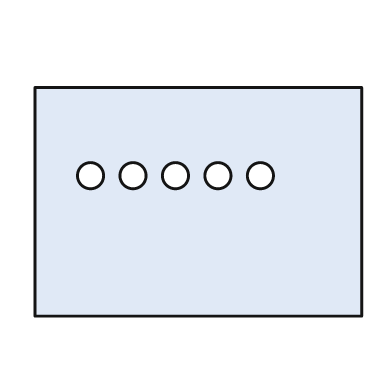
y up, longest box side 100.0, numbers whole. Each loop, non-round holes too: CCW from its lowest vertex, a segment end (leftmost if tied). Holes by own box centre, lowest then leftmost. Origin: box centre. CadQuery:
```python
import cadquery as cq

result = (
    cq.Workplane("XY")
    .moveTo(-50.0, -35.0)
    .lineTo(50.0, -35.0)
    .lineTo(50.0, 35.0)
    .lineTo(-50.0, 35.0)
    .close()
    .moveTo(-33.0, 8.0)
    .circle(4.0)
    .moveTo(-20.0, 8.0)
    .circle(4.0)
    .moveTo(-7.0, 8.0)
    .circle(4.0)
    .moveTo(6.0, 8.0)
    .circle(4.0)
    .moveTo(19.0, 8.0)
    .circle(4.0)
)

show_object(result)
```